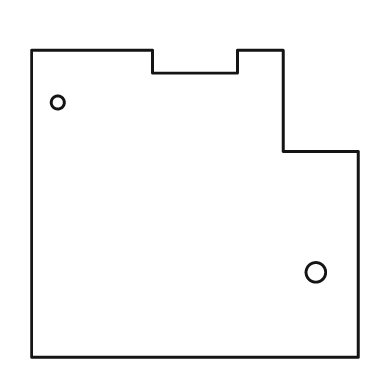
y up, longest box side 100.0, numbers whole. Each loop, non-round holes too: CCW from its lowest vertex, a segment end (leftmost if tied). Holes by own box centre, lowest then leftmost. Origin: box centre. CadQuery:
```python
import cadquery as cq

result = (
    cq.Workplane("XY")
    .moveTo(-50.0, -47.0)
    .lineTo(50.0, -47.0)
    .lineTo(50.0, 16.0)
    .lineTo(27.0, 16.0)
    .lineTo(27.0, 47.0)
    .lineTo(13.0, 47.0)
    .lineTo(13.0, 40.0)
    .lineTo(-13.0, 40.0)
    .lineTo(-13.0, 47.0)
    .lineTo(-50.0, 47.0)
    .close()
    .moveTo(37.0, -21.0)
    .circle(3.0)
    .moveTo(-42.0, 31.0)
    .circle(2.0)
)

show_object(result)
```